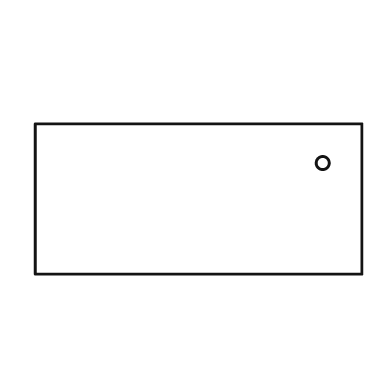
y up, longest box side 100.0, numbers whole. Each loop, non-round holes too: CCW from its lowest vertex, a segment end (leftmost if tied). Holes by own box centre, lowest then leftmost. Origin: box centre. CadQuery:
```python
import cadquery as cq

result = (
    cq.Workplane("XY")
    .moveTo(-50.0, -23.0)
    .lineTo(50.0, -23.0)
    .lineTo(50.0, 23.0)
    .lineTo(-50.0, 23.0)
    .close()
    .moveTo(38.0, 11.0)
    .circle(2.0)
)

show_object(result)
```